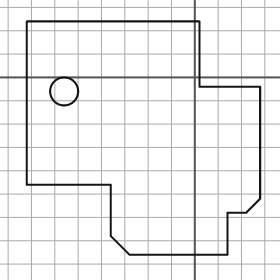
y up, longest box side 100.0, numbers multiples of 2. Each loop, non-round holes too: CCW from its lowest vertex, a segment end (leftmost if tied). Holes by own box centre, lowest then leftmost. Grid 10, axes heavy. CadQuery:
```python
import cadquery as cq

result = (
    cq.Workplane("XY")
    .moveTo(-28.0, -76.0)
    .lineTo(14.0, -76.0)
    .lineTo(14.0, -58.0)
    .lineTo(22.0, -58.0)
    .lineTo(28.0, -52.0)
    .lineTo(28.0, -4.0)
    .lineTo(2.0, -4.0)
    .lineTo(2.0, 24.0)
    .lineTo(-72.0, 24.0)
    .lineTo(-72.0, -46.0)
    .lineTo(-36.0, -46.0)
    .lineTo(-36.0, -68.0)
    .close()
    .moveTo(-56.0, -6.0)
    .circle(6.0)
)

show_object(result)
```